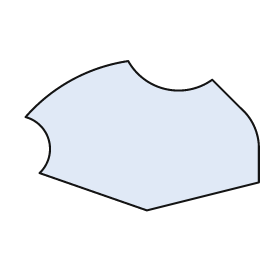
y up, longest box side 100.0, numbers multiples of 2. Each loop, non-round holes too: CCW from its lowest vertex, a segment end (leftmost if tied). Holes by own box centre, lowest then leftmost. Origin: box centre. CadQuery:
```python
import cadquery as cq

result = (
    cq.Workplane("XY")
    .moveTo(2.0, -32.0)
    .lineTo(50.0, -20.0)
    .lineTo(50.0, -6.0)
    .threePointArc((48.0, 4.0), (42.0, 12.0))
    .lineTo(30.0, 24.0)
    .threePointArc((10.0, 20.0), (-6.0, 32.0))
    .threePointArc((-30.0, 24.0), (-50.0, 8.0))
    .threePointArc((-40.0, -2.0), (-44.0, -16.0))
    .close()
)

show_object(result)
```